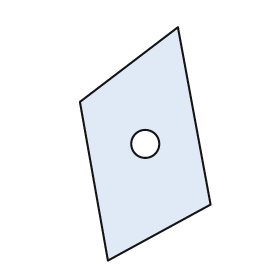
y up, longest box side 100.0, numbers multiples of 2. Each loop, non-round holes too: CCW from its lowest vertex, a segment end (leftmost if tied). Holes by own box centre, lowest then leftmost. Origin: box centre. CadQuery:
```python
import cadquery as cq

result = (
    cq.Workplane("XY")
    .moveTo(-16.0, -50.0)
    .lineTo(28.0, -26.0)
    .lineTo(14.0, 50.0)
    .lineTo(-28.0, 18.0)
    .close()
    .moveTo(0.0, 0.0)
    .circle(6.0)
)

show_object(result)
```